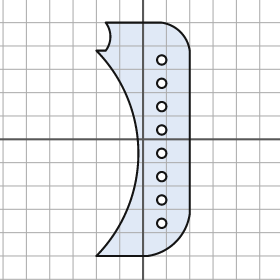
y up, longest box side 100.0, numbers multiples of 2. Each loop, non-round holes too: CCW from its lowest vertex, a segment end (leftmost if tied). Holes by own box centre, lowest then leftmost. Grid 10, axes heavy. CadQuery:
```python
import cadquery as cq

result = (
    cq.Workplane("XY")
    .moveTo(-20.0, -50.0)
    .lineTo(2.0, -50.0)
    .threePointArc((14.0, -44.0), (20.0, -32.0))
    .lineTo(20.0, 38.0)
    .threePointArc((16.0, 46.0), (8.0, 50.0))
    .lineTo(-16.0, 50.0)
    .threePointArc((-14.0, 44.0), (-16.0, 38.0))
    .lineTo(-20.0, 38.0)
    .threePointArc((-2.0, -6.0), (-20.0, -50.0))
    .close()
    .moveTo(8.0, -36.0)
    .circle(2.0)
    .moveTo(8.0, -26.0)
    .circle(2.0)
    .moveTo(8.0, -16.0)
    .circle(2.0)
    .moveTo(8.0, -6.0)
    .circle(2.0)
    .moveTo(8.0, 4.0)
    .circle(2.0)
    .moveTo(8.0, 14.0)
    .circle(2.0)
    .moveTo(8.0, 24.0)
    .circle(2.0)
    .moveTo(8.0, 34.0)
    .circle(2.0)
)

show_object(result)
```